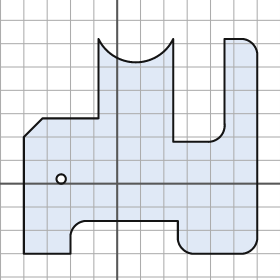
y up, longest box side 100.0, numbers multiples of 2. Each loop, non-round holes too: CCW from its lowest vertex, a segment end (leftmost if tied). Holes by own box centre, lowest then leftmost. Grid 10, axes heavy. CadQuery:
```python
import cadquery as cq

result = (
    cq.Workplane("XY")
    .moveTo(-40.0, -30.0)
    .lineTo(-20.0, -30.0)
    .lineTo(-20.0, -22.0)
    .threePointArc((-18.0, -18.0), (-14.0, -16.0))
    .lineTo(26.0, -16.0)
    .lineTo(26.0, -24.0)
    .threePointArc((28.0, -28.0), (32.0, -30.0))
    .lineTo(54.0, -30.0)
    .threePointArc((58.0, -28.0), (60.0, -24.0))
    .lineTo(60.0, 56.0)
    .threePointArc((58.0, 60.0), (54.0, 62.0))
    .lineTo(46.0, 62.0)
    .lineTo(46.0, 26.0)
    .threePointArc((44.0, 20.0), (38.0, 18.0))
    .lineTo(24.0, 18.0)
    .lineTo(24.0, 62.0)
    .threePointArc((8.0, 52.0), (-8.0, 62.0))
    .lineTo(-8.0, 28.0)
    .lineTo(-32.0, 28.0)
    .lineTo(-40.0, 20.0)
    .close()
    .moveTo(-24.0, 2.0)
    .circle(2.0)
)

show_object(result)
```